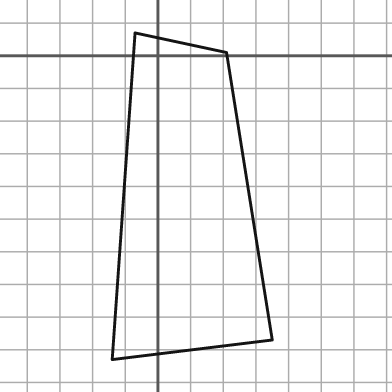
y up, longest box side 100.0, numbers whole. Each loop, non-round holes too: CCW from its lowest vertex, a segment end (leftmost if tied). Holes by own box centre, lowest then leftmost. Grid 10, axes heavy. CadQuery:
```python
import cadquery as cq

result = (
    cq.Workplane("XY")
    .moveTo(-14.0, -93.0)
    .lineTo(35.0, -87.0)
    .lineTo(21.0, 1.0)
    .lineTo(-7.0, 7.0)
    .close()
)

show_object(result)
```